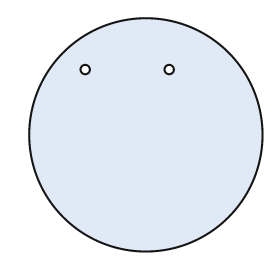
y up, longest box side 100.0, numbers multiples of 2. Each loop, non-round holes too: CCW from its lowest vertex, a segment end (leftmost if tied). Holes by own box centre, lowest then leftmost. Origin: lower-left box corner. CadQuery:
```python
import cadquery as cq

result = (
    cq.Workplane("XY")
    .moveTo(50.0, 50.0)
    .circle(50.0)
    .moveTo(24.0, 78.0)
    .circle(2.0)
    .moveTo(60.0, 78.0)
    .circle(2.0)
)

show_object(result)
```